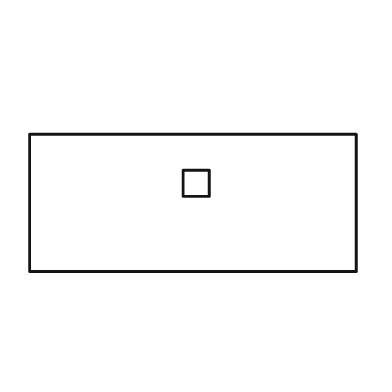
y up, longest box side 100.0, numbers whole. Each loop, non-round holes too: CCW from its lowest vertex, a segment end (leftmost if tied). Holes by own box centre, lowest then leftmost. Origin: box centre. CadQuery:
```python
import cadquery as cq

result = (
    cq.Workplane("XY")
    .moveTo(-50.0, -21.0)
    .lineTo(50.0, -21.0)
    .lineTo(50.0, 21.0)
    .lineTo(-50.0, 21.0)
    .close()
    .moveTo(-3.0, 2.0)
    .lineTo(5.0, 2.0)
    .lineTo(5.0, 10.0)
    .lineTo(-3.0, 10.0)
    .close()
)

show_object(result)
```